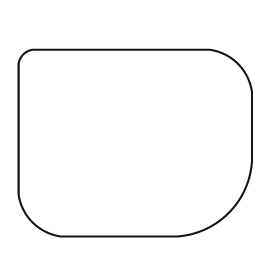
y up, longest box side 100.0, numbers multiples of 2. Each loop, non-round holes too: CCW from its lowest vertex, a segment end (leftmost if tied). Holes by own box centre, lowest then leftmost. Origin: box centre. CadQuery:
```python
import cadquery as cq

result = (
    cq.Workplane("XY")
    .moveTo(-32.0, -40.0)
    .lineTo(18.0, -40.0)
    .threePointArc((40.0, -30.0), (50.0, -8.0))
    .lineTo(50.0, 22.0)
    .threePointArc((44.0, 34.0), (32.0, 40.0))
    .lineTo(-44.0, 40.0)
    .threePointArc((-48.0, 38.0), (-50.0, 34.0))
    .lineTo(-50.0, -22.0)
    .threePointArc((-44.0, -34.0), (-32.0, -40.0))
    .close()
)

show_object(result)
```